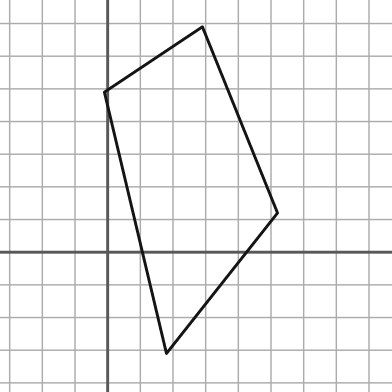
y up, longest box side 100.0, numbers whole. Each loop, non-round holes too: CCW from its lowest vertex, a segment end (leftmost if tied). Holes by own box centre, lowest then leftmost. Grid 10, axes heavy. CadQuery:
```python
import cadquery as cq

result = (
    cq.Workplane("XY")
    .moveTo(18.0, -31.0)
    .lineTo(52.0, 12.0)
    .lineTo(29.0, 69.0)
    .lineTo(-1.0, 49.0)
    .close()
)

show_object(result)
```